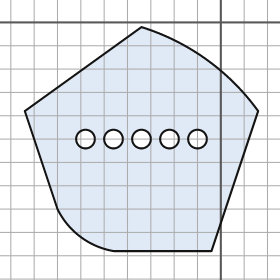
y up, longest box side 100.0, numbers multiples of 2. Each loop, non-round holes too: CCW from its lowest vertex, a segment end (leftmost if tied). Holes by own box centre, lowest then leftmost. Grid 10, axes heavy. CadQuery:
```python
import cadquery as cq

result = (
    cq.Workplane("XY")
    .moveTo(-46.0, -98.0)
    .lineTo(-4.0, -98.0)
    .lineTo(16.0, -38.0)
    .threePointArc((-6.0, -16.0), (-34.0, -2.0))
    .lineTo(-84.0, -38.0)
    .lineTo(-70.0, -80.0)
    .threePointArc((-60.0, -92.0), (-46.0, -98.0))
    .close()
    .moveTo(-58.0, -50.0)
    .circle(4.0)
    .moveTo(-46.0, -50.0)
    .circle(4.0)
    .moveTo(-34.0, -50.0)
    .circle(4.0)
    .moveTo(-22.0, -50.0)
    .circle(4.0)
    .moveTo(-10.0, -50.0)
    .circle(4.0)
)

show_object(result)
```